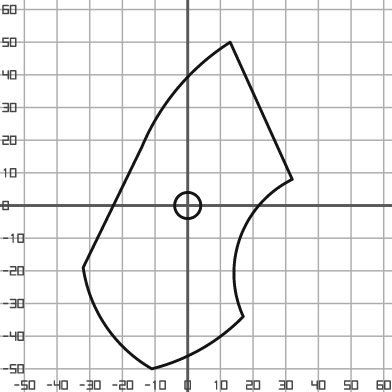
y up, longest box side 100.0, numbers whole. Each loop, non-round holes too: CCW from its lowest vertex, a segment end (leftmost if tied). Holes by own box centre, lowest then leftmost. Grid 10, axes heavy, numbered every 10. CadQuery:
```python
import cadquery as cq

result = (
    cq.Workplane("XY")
    .moveTo(-11.0, -50.0)
    .threePointArc((4.0, -44.0), (17.0, -34.0))
    .threePointArc((16.0, -10.0), (32.0, 8.0))
    .lineTo(13.0, 50.0)
    .threePointArc((-3.0, 36.0), (-14.0, 18.0))
    .lineTo(-32.0, -19.0)
    .threePointArc((-25.0, -37.0), (-11.0, -50.0))
    .close()
    .moveTo(0.0, 0.0)
    .circle(4.0)
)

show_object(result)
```